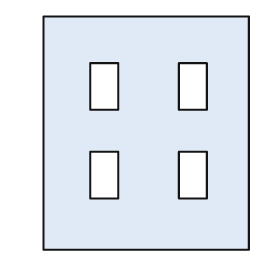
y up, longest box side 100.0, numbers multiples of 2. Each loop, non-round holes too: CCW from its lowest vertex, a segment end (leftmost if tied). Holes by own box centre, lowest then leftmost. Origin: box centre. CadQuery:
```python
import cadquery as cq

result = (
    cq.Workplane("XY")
    .moveTo(-44.0, -50.0)
    .lineTo(44.0, -50.0)
    .lineTo(44.0, 50.0)
    .lineTo(-44.0, 50.0)
    .close()
    .moveTo(-24.0, -28.0)
    .lineTo(-12.0, -28.0)
    .lineTo(-12.0, -8.0)
    .lineTo(-24.0, -8.0)
    .close()
    .moveTo(14.0, -28.0)
    .lineTo(26.0, -28.0)
    .lineTo(26.0, -8.0)
    .lineTo(14.0, -8.0)
    .close()
    .moveTo(-24.0, 10.0)
    .lineTo(-12.0, 10.0)
    .lineTo(-12.0, 30.0)
    .lineTo(-24.0, 30.0)
    .close()
    .moveTo(14.0, 10.0)
    .lineTo(26.0, 10.0)
    .lineTo(26.0, 30.0)
    .lineTo(14.0, 30.0)
    .close()
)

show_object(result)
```